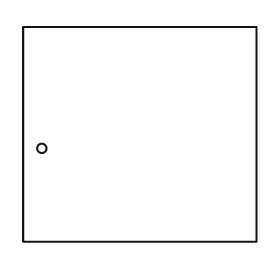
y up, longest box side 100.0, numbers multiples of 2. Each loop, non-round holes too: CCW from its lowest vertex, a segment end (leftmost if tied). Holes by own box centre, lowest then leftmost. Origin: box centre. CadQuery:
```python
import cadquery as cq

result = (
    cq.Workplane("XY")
    .moveTo(-50.0, -46.0)
    .lineTo(50.0, -46.0)
    .lineTo(50.0, 46.0)
    .lineTo(-50.0, 46.0)
    .close()
    .moveTo(-42.0, -6.0)
    .circle(2.0)
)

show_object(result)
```